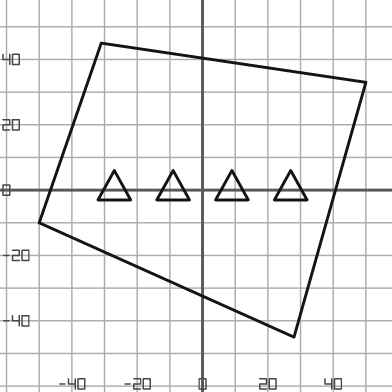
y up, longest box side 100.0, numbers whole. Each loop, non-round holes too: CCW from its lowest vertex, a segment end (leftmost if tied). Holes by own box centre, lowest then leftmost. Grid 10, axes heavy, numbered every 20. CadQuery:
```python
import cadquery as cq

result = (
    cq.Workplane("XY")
    .moveTo(28.0, -45.0)
    .lineTo(50.0, 33.0)
    .lineTo(-31.0, 45.0)
    .lineTo(-50.0, -10.0)
    .close()
    .moveTo(-32.0, -3.0)
    .lineTo(-22.0, -3.0)
    .lineTo(-27.0, 6.0)
    .close()
    .moveTo(-14.0, -3.0)
    .lineTo(-4.0, -3.0)
    .lineTo(-9.0, 6.0)
    .close()
    .moveTo(4.0, -3.0)
    .lineTo(14.0, -3.0)
    .lineTo(9.0, 6.0)
    .close()
    .moveTo(22.0, -3.0)
    .lineTo(32.0, -3.0)
    .lineTo(27.0, 6.0)
    .close()
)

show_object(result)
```